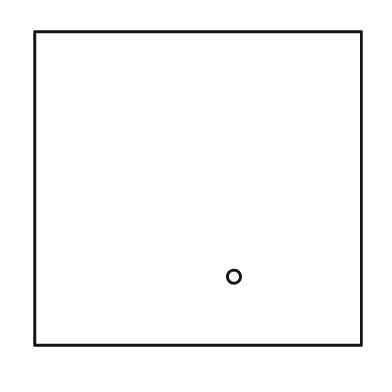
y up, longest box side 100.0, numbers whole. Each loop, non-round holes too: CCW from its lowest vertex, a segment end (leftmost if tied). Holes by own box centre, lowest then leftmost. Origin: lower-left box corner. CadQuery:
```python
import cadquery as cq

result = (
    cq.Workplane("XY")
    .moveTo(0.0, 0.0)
    .lineTo(100.0, 0.0)
    .lineTo(100.0, 96.0)
    .lineTo(0.0, 96.0)
    .close()
    .moveTo(61.0, 21.0)
    .circle(2.0)
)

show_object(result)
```